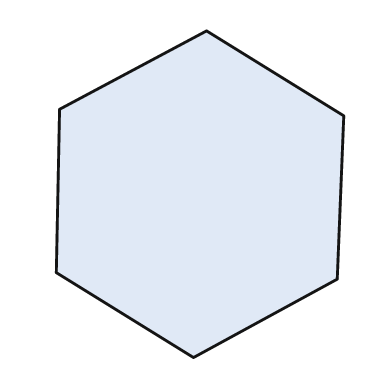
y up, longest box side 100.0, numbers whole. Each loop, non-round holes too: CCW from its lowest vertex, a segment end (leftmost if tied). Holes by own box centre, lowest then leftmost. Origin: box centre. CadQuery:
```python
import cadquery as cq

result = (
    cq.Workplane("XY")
    .moveTo(-2.0, -50.0)
    .lineTo(42.0, -26.0)
    .lineTo(44.0, 24.0)
    .lineTo(2.0, 50.0)
    .lineTo(-43.0, 26.0)
    .lineTo(-44.0, -24.0)
    .close()
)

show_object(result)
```